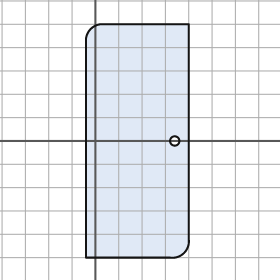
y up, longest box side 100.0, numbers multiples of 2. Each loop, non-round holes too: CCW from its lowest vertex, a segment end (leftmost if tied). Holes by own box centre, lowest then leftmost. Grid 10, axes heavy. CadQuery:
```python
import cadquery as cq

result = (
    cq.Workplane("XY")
    .moveTo(-4.0, -50.0)
    .lineTo(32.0, -50.0)
    .threePointArc((38.0, -48.0), (40.0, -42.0))
    .lineTo(40.0, 50.0)
    .lineTo(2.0, 50.0)
    .threePointArc((-2.0, 48.0), (-4.0, 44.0))
    .close()
    .moveTo(34.0, 0.0)
    .circle(2.0)
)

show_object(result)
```